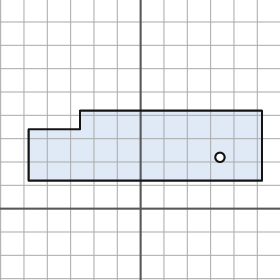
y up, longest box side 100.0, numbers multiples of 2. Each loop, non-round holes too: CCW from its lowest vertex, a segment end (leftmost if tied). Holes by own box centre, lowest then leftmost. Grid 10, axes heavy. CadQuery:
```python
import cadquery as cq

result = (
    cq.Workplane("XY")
    .moveTo(-48.0, 12.0)
    .lineTo(52.0, 12.0)
    .lineTo(52.0, 42.0)
    .lineTo(-26.0, 42.0)
    .lineTo(-26.0, 34.0)
    .lineTo(-48.0, 34.0)
    .close()
    .moveTo(34.0, 22.0)
    .circle(2.0)
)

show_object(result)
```